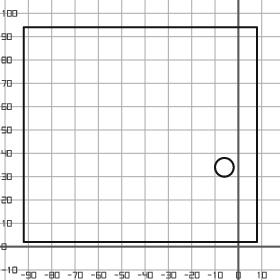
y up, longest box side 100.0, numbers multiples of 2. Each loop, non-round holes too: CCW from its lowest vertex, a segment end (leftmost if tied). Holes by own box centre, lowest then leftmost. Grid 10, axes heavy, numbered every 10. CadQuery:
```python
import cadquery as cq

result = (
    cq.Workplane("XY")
    .moveTo(-92.0, 2.0)
    .lineTo(8.0, 2.0)
    .lineTo(8.0, 94.0)
    .lineTo(-92.0, 94.0)
    .close()
    .moveTo(-6.0, 34.0)
    .circle(4.0)
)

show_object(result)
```